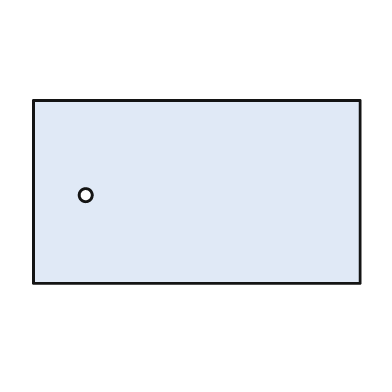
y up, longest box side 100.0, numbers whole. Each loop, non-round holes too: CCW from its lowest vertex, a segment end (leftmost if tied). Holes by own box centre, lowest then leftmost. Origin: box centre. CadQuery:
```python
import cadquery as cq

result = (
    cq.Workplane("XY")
    .moveTo(-50.0, -28.0)
    .lineTo(50.0, -28.0)
    .lineTo(50.0, 28.0)
    .lineTo(-50.0, 28.0)
    .close()
    .moveTo(-34.0, -1.0)
    .circle(2.0)
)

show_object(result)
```